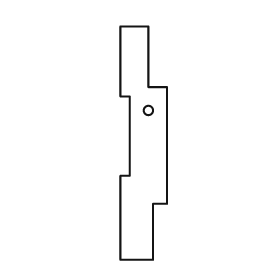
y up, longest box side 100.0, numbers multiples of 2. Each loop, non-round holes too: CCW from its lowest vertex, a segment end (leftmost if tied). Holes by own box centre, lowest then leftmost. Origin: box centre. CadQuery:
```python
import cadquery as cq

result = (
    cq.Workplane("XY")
    .moveTo(-10.0, -50.0)
    .lineTo(4.0, -50.0)
    .lineTo(4.0, -26.0)
    .lineTo(10.0, -26.0)
    .lineTo(10.0, 24.0)
    .lineTo(2.0, 24.0)
    .lineTo(2.0, 50.0)
    .lineTo(-10.0, 50.0)
    .lineTo(-10.0, 20.0)
    .lineTo(-6.0, 20.0)
    .lineTo(-6.0, -14.0)
    .lineTo(-10.0, -14.0)
    .close()
    .moveTo(2.0, 14.0)
    .circle(2.0)
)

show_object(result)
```